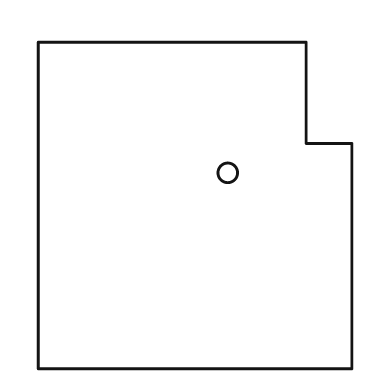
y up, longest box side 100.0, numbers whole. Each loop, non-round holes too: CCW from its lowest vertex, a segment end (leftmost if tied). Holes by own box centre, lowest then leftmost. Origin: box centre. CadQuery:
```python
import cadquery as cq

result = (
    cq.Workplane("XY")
    .moveTo(-48.0, -50.0)
    .lineTo(48.0, -50.0)
    .lineTo(48.0, 19.0)
    .lineTo(34.0, 19.0)
    .lineTo(34.0, 50.0)
    .lineTo(-48.0, 50.0)
    .close()
    .moveTo(10.0, 10.0)
    .circle(3.0)
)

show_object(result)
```